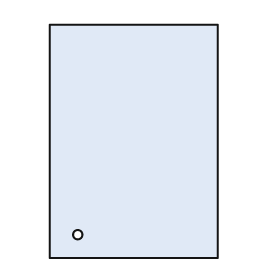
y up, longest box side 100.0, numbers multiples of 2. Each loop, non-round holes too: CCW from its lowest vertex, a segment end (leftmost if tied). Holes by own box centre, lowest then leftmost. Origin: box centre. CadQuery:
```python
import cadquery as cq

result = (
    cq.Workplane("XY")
    .moveTo(-36.0, -50.0)
    .lineTo(36.0, -50.0)
    .lineTo(36.0, 50.0)
    .lineTo(-36.0, 50.0)
    .close()
    .moveTo(-24.0, -40.0)
    .circle(2.0)
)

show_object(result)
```